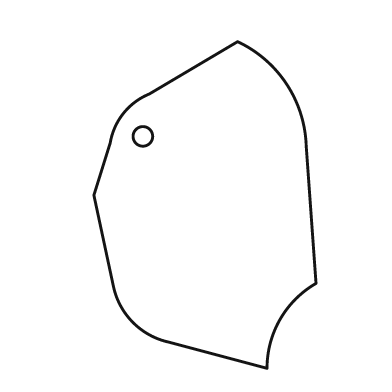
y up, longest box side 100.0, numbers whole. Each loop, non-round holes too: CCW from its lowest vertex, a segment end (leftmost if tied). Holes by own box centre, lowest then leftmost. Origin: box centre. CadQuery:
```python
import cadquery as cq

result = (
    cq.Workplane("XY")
    .moveTo(19.0, -50.0)
    .threePointArc((23.0, -35.0), (34.0, -24.0))
    .lineTo(31.0, 18.0)
    .threePointArc((25.0, 37.0), (10.0, 50.0))
    .lineTo(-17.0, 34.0)
    .threePointArc((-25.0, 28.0), (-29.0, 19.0))
    .lineTo(-34.0, 3.0)
    .lineTo(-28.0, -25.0)
    .threePointArc((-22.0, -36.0), (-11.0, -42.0))
    .close()
    .moveTo(-19.0, 21.0)
    .circle(3.0)
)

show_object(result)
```